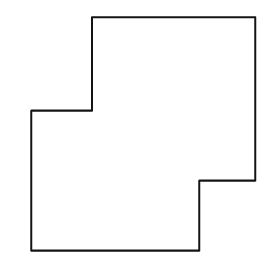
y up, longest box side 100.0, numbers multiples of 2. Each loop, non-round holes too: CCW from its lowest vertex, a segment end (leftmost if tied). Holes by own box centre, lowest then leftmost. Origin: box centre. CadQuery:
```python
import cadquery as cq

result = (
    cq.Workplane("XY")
    .moveTo(-48.0, -50.0)
    .lineTo(24.0, -50.0)
    .lineTo(24.0, -20.0)
    .lineTo(48.0, -20.0)
    .lineTo(48.0, 50.0)
    .lineTo(-22.0, 50.0)
    .lineTo(-22.0, 10.0)
    .lineTo(-48.0, 10.0)
    .close()
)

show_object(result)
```